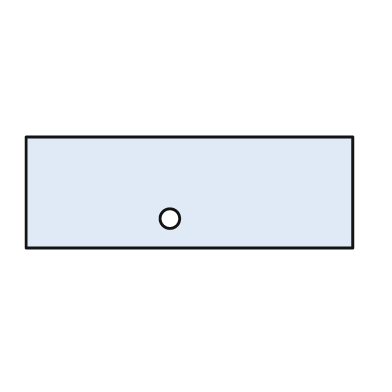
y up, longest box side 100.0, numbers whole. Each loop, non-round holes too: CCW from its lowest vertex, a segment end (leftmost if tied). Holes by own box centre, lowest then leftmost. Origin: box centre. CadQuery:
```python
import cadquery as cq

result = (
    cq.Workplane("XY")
    .moveTo(-50.0, -17.0)
    .lineTo(50.0, -17.0)
    .lineTo(50.0, 17.0)
    .lineTo(-50.0, 17.0)
    .close()
    .moveTo(-6.0, -8.0)
    .circle(3.0)
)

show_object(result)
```